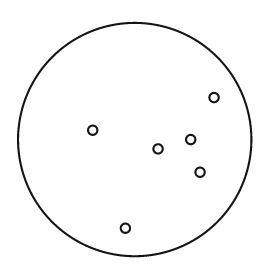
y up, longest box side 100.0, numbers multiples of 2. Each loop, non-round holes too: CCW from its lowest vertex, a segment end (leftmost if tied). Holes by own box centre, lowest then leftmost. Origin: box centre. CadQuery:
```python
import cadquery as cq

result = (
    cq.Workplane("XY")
    .moveTo(0.0, 0.0)
    .circle(50.0)
    .moveTo(-4.0, -38.0)
    .circle(2.0)
    .moveTo(28.0, -14.0)
    .circle(2.0)
    .moveTo(10.0, -4.0)
    .circle(2.0)
    .moveTo(24.0, 0.0)
    .circle(2.0)
    .moveTo(-18.0, 4.0)
    .circle(2.0)
    .moveTo(34.0, 18.0)
    .circle(2.0)
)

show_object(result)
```